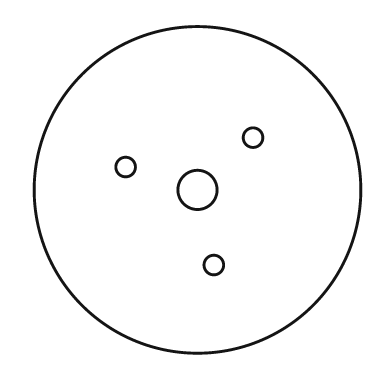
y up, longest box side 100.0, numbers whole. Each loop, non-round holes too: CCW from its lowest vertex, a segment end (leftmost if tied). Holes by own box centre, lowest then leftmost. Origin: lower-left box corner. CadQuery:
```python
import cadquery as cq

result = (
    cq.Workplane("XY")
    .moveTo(50.0, 50.0)
    .circle(50.0)
    .moveTo(55.0, 27.0)
    .circle(3.0)
    .moveTo(50.0, 50.0)
    .circle(6.0)
    .moveTo(28.0, 57.0)
    .circle(3.0)
    .moveTo(67.0, 66.0)
    .circle(3.0)
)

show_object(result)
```